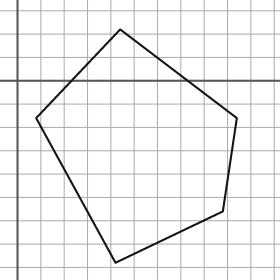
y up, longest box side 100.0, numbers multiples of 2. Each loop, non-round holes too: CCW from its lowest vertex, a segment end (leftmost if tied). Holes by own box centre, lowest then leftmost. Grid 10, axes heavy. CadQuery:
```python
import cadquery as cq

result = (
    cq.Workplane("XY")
    .moveTo(42.0, -78.0)
    .lineTo(88.0, -56.0)
    .lineTo(94.0, -16.0)
    .lineTo(44.0, 22.0)
    .lineTo(8.0, -16.0)
    .close()
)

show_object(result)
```